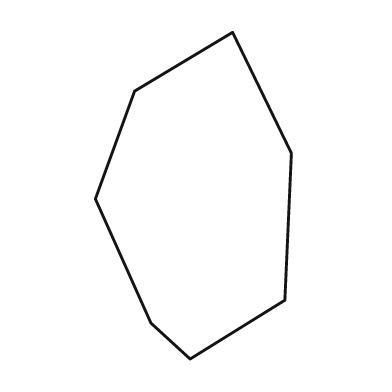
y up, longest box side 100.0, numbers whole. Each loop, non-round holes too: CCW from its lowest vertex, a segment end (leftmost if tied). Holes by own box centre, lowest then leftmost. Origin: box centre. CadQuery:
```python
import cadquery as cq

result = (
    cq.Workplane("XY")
    .moveTo(-1.0, -50.0)
    .lineTo(28.0, -32.0)
    .lineTo(30.0, 13.0)
    .lineTo(12.0, 50.0)
    .lineTo(-18.0, 32.0)
    .lineTo(-30.0, -1.0)
    .lineTo(-13.0, -39.0)
    .close()
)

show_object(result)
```